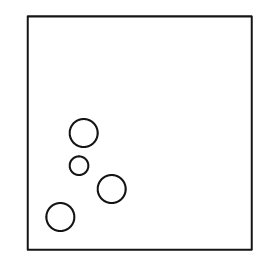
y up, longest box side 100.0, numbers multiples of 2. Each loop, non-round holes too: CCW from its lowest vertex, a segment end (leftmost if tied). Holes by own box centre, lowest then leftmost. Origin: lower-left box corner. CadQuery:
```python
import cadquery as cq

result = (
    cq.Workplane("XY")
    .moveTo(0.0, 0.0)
    .lineTo(96.0, 0.0)
    .lineTo(96.0, 100.0)
    .lineTo(0.0, 100.0)
    .close()
    .moveTo(14.0, 14.0)
    .circle(6.0)
    .moveTo(36.0, 26.0)
    .circle(6.0)
    .moveTo(22.0, 36.0)
    .circle(4.0)
    .moveTo(24.0, 50.0)
    .circle(6.0)
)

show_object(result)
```